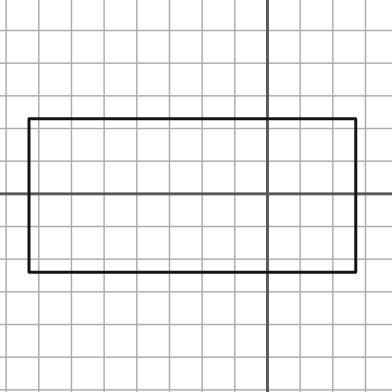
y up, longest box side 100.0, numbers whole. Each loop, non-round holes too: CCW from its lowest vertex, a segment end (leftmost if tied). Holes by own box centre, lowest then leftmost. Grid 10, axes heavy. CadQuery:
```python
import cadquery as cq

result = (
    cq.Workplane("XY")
    .moveTo(-73.0, -24.0)
    .lineTo(27.0, -24.0)
    .lineTo(27.0, 23.0)
    .lineTo(-73.0, 23.0)
    .close()
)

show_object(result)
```